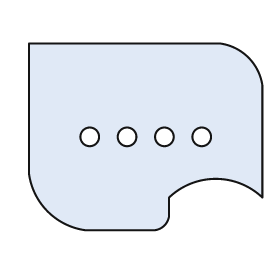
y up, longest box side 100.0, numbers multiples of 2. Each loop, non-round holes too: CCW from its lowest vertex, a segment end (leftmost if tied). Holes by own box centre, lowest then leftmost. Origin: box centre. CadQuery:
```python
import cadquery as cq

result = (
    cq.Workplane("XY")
    .moveTo(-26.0, -40.0)
    .lineTo(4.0, -40.0)
    .threePointArc((8.0, -38.0), (10.0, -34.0))
    .lineTo(10.0, -26.0)
    .threePointArc((30.0, -18.0), (50.0, -26.0))
    .lineTo(50.0, 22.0)
    .threePointArc((44.0, 34.0), (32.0, 40.0))
    .lineTo(-50.0, 40.0)
    .lineTo(-50.0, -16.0)
    .threePointArc((-42.0, -32.0), (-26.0, -40.0))
    .close()
    .moveTo(-24.0, 0.0)
    .circle(4.0)
    .moveTo(-8.0, 0.0)
    .circle(4.0)
    .moveTo(8.0, 0.0)
    .circle(4.0)
    .moveTo(24.0, 0.0)
    .circle(4.0)
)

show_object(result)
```